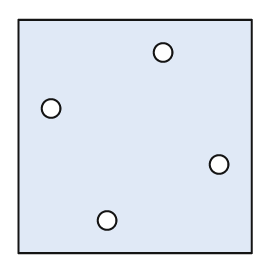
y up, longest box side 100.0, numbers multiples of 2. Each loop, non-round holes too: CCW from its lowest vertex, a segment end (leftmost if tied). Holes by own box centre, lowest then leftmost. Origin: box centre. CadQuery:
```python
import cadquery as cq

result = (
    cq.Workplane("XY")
    .moveTo(-50.0, -50.0)
    .lineTo(50.0, -50.0)
    .lineTo(50.0, 50.0)
    .lineTo(-50.0, 50.0)
    .close()
    .moveTo(-12.0, -36.0)
    .circle(4.0)
    .moveTo(36.0, -12.0)
    .circle(4.0)
    .moveTo(-36.0, 12.0)
    .circle(4.0)
    .moveTo(12.0, 36.0)
    .circle(4.0)
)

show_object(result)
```